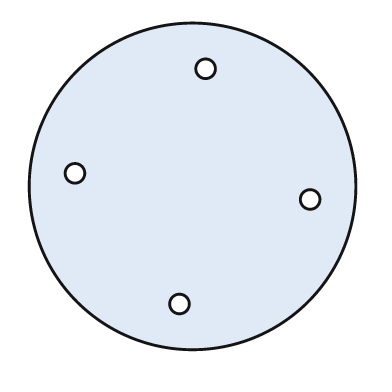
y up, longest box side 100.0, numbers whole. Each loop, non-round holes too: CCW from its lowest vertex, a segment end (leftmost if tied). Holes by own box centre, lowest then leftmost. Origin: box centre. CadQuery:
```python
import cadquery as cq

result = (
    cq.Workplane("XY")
    .moveTo(0.0, 0.0)
    .circle(50.0)
    .moveTo(-4.0, -36.0)
    .circle(3.0)
    .moveTo(36.0, -4.0)
    .circle(3.0)
    .moveTo(-36.0, 4.0)
    .circle(3.0)
    .moveTo(4.0, 36.0)
    .circle(3.0)
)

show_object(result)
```